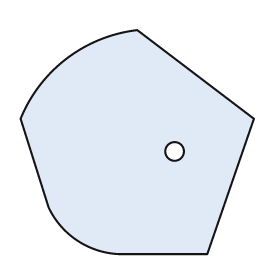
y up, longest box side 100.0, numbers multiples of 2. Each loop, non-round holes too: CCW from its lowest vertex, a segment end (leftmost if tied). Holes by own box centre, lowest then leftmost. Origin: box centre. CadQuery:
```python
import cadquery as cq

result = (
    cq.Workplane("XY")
    .moveTo(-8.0, -48.0)
    .lineTo(30.0, -48.0)
    .lineTo(50.0, 10.0)
    .lineTo(0.0, 48.0)
    .threePointArc((-30.0, 36.0), (-50.0, 10.0))
    .lineTo(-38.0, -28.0)
    .threePointArc((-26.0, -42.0), (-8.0, -48.0))
    .close()
    .moveTo(16.0, -4.0)
    .circle(4.0)
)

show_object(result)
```